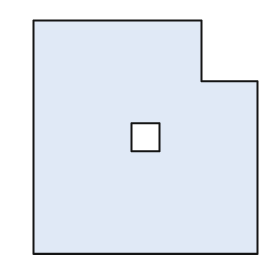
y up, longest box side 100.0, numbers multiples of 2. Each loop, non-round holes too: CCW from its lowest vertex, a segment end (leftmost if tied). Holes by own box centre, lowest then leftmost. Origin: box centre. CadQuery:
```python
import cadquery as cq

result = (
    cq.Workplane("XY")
    .moveTo(-48.0, -50.0)
    .lineTo(48.0, -50.0)
    .lineTo(48.0, 24.0)
    .lineTo(24.0, 24.0)
    .lineTo(24.0, 50.0)
    .lineTo(-48.0, 50.0)
    .close()
    .moveTo(-6.0, -6.0)
    .lineTo(6.0, -6.0)
    .lineTo(6.0, 6.0)
    .lineTo(-6.0, 6.0)
    .close()
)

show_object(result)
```